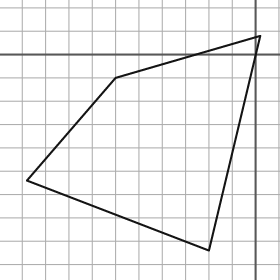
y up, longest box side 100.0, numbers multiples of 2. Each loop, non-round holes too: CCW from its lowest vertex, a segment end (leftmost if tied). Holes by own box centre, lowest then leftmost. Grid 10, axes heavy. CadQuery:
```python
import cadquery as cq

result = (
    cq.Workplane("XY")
    .moveTo(-20.0, -84.0)
    .lineTo(2.0, 8.0)
    .lineTo(-60.0, -10.0)
    .lineTo(-98.0, -54.0)
    .close()
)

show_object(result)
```